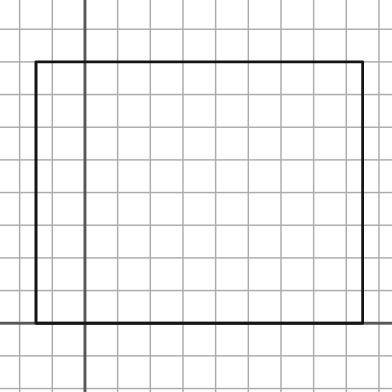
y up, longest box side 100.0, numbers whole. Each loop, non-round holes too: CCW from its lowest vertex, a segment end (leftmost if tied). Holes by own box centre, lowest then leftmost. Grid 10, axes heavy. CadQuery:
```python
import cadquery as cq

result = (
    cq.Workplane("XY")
    .moveTo(-15.0, 0.0)
    .lineTo(85.0, 0.0)
    .lineTo(85.0, 80.0)
    .lineTo(-15.0, 80.0)
    .close()
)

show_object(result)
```